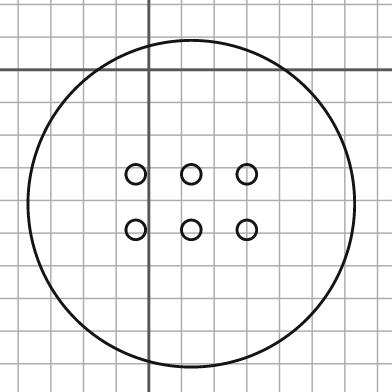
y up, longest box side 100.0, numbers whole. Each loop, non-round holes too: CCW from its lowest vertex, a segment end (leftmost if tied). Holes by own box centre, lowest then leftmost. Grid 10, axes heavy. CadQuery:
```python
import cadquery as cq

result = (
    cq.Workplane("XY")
    .moveTo(13.0, -41.0)
    .circle(50.0)
    .moveTo(-4.0, -49.0)
    .circle(3.0)
    .moveTo(13.0, -49.0)
    .circle(3.0)
    .moveTo(30.0, -49.0)
    .circle(3.0)
    .moveTo(-4.0, -32.0)
    .circle(3.0)
    .moveTo(13.0, -32.0)
    .circle(3.0)
    .moveTo(30.0, -32.0)
    .circle(3.0)
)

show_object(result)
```